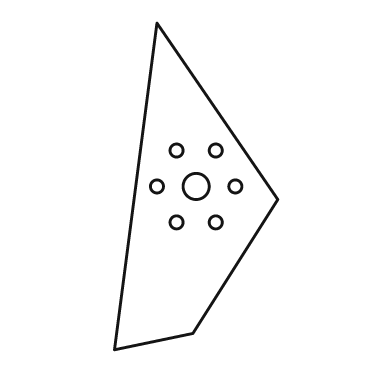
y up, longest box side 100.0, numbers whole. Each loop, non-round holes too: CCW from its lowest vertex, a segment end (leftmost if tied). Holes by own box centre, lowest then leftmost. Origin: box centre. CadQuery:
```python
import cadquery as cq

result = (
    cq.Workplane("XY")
    .moveTo(-25.0, -50.0)
    .lineTo(-1.0, -45.0)
    .lineTo(25.0, -4.0)
    .lineTo(-12.0, 50.0)
    .close()
    .moveTo(-6.0, -11.0)
    .circle(2.0)
    .moveTo(6.0, -11.0)
    .circle(2.0)
    .moveTo(-12.0, 0.0)
    .circle(2.0)
    .moveTo(0.0, 0.0)
    .circle(4.0)
    .moveTo(12.0, 0.0)
    .circle(2.0)
    .moveTo(-6.0, 11.0)
    .circle(2.0)
    .moveTo(6.0, 11.0)
    .circle(2.0)
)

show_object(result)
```